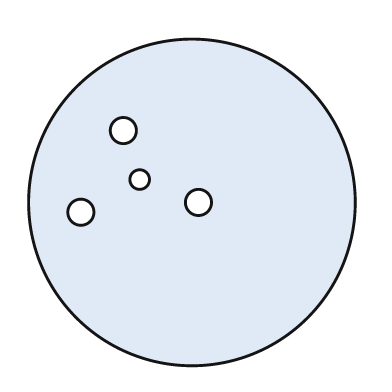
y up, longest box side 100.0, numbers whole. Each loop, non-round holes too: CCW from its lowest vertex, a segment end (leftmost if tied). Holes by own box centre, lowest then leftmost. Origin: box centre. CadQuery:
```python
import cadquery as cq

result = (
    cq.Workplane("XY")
    .moveTo(0.0, 0.0)
    .circle(50.0)
    .moveTo(-34.0, -3.0)
    .circle(4.0)
    .moveTo(2.0, 0.0)
    .circle(4.0)
    .moveTo(-16.0, 7.0)
    .circle(3.0)
    .moveTo(-21.0, 22.0)
    .circle(4.0)
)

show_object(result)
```